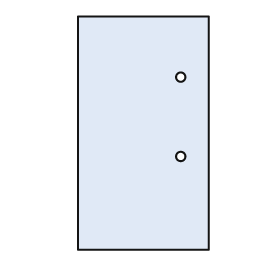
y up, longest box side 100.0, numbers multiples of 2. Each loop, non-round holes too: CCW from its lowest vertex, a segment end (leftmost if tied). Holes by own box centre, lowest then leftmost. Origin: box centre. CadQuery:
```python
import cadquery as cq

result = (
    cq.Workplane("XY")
    .moveTo(-28.0, -50.0)
    .lineTo(28.0, -50.0)
    .lineTo(28.0, 50.0)
    .lineTo(-28.0, 50.0)
    .close()
    .moveTo(16.0, -10.0)
    .circle(2.0)
    .moveTo(16.0, 24.0)
    .circle(2.0)
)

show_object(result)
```